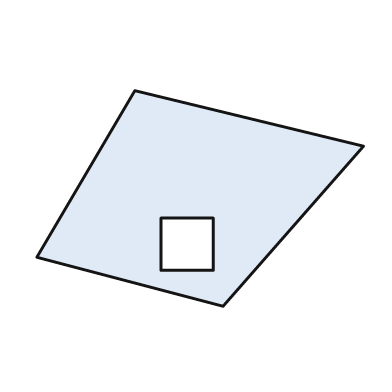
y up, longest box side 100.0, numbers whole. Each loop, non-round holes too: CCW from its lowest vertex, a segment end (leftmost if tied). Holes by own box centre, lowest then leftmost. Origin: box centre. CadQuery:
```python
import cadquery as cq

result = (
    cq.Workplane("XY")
    .moveTo(7.0, -33.0)
    .lineTo(50.0, 16.0)
    .lineTo(-20.0, 33.0)
    .lineTo(-50.0, -18.0)
    .close()
    .moveTo(-12.0, -22.0)
    .lineTo(4.0, -22.0)
    .lineTo(4.0, -6.0)
    .lineTo(-12.0, -6.0)
    .close()
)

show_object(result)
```